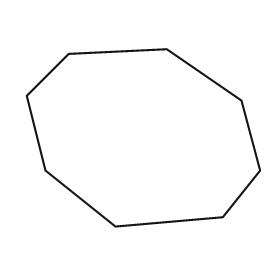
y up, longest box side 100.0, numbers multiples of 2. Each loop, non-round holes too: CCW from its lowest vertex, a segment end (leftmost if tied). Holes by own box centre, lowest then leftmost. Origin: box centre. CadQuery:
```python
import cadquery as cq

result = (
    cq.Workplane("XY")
    .moveTo(-12.0, -38.0)
    .lineTo(34.0, -34.0)
    .lineTo(50.0, -14.0)
    .lineTo(42.0, 16.0)
    .lineTo(10.0, 38.0)
    .lineTo(-32.0, 36.0)
    .lineTo(-50.0, 18.0)
    .lineTo(-42.0, -14.0)
    .close()
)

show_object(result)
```